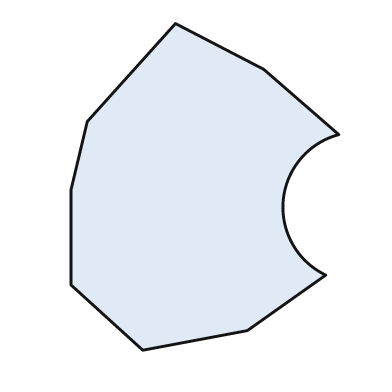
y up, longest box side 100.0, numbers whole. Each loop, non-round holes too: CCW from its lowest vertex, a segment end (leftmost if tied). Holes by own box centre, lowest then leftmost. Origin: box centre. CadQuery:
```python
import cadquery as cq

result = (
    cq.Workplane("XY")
    .moveTo(-19.0, -50.0)
    .lineTo(13.0, -44.0)
    .lineTo(37.0, -27.0)
    .threePointArc((24.0, -4.0), (41.0, 16.0))
    .lineTo(18.0, 36.0)
    .lineTo(-9.0, 50.0)
    .lineTo(-36.0, 20.0)
    .lineTo(-41.0, -1.0)
    .lineTo(-41.0, -30.0)
    .close()
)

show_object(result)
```